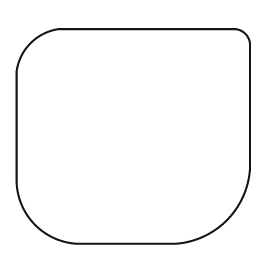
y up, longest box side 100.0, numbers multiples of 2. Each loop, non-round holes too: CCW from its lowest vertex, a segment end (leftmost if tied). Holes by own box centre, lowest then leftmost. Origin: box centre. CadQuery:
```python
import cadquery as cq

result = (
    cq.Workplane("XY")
    .moveTo(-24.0, -46.0)
    .lineTo(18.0, -46.0)
    .threePointArc((40.0, -36.0), (50.0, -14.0))
    .lineTo(50.0, 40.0)
    .threePointArc((48.0, 44.0), (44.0, 46.0))
    .lineTo(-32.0, 46.0)
    .threePointArc((-44.0, 40.0), (-50.0, 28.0))
    .lineTo(-50.0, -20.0)
    .threePointArc((-42.0, -38.0), (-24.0, -46.0))
    .close()
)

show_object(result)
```